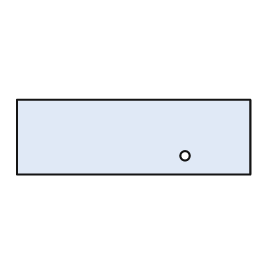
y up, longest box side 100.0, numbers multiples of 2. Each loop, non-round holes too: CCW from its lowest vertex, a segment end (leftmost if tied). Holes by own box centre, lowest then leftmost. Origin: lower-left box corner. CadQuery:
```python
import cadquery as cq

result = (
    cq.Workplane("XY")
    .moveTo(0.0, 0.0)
    .lineTo(100.0, 0.0)
    .lineTo(100.0, 32.0)
    .lineTo(0.0, 32.0)
    .close()
    .moveTo(72.0, 8.0)
    .circle(2.0)
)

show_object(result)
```